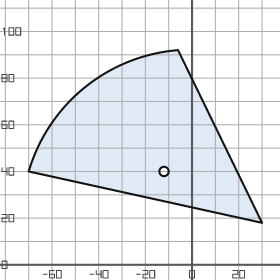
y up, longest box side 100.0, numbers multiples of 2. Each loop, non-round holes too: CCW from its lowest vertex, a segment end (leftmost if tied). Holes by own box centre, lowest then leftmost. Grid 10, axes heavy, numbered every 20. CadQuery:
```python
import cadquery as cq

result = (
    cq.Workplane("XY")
    .moveTo(30.0, 18.0)
    .lineTo(-6.0, 92.0)
    .threePointArc((-46.0, 76.0), (-70.0, 40.0))
    .close()
    .moveTo(-12.0, 40.0)
    .circle(2.0)
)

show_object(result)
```